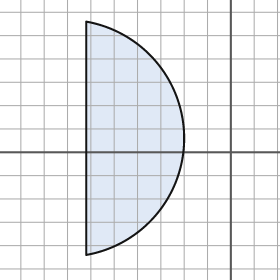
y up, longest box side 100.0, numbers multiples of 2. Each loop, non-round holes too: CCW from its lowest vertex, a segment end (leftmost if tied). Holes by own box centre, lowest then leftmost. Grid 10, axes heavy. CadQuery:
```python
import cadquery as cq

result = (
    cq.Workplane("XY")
    .moveTo(-62.0, -44.0)
    .threePointArc((-20.0, 6.0), (-62.0, 56.0))
    .close()
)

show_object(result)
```